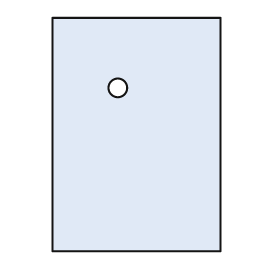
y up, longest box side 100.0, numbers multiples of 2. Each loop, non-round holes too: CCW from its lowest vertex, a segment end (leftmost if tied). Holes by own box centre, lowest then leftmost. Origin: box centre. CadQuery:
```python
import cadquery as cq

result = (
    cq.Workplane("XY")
    .moveTo(-36.0, -50.0)
    .lineTo(36.0, -50.0)
    .lineTo(36.0, 50.0)
    .lineTo(-36.0, 50.0)
    .close()
    .moveTo(-8.0, 20.0)
    .circle(4.0)
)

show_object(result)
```